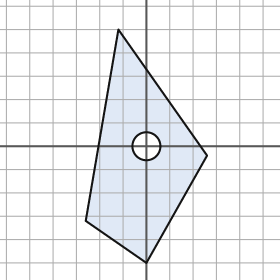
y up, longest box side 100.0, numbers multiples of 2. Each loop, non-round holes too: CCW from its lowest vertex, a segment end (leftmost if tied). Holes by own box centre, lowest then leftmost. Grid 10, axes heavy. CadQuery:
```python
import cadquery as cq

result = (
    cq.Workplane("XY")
    .moveTo(0.0, -50.0)
    .lineTo(26.0, -4.0)
    .lineTo(-12.0, 50.0)
    .lineTo(-26.0, -32.0)
    .close()
    .moveTo(0.0, 0.0)
    .circle(6.0)
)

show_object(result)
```